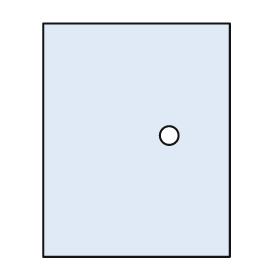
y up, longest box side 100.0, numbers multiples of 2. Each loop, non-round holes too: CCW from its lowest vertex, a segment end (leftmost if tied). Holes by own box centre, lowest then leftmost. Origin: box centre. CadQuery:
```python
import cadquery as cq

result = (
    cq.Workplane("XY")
    .moveTo(-40.0, -50.0)
    .lineTo(40.0, -50.0)
    .lineTo(40.0, 50.0)
    .lineTo(-40.0, 50.0)
    .close()
    .moveTo(14.0, 2.0)
    .circle(4.0)
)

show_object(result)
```